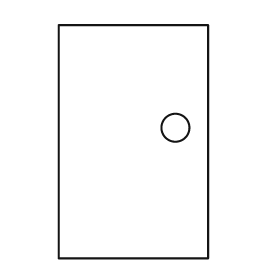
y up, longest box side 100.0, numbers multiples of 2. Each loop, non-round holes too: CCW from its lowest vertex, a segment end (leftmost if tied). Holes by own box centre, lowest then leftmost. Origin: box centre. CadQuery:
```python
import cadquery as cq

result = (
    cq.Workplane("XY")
    .moveTo(-32.0, -50.0)
    .lineTo(32.0, -50.0)
    .lineTo(32.0, 50.0)
    .lineTo(-32.0, 50.0)
    .close()
    .moveTo(18.0, 6.0)
    .circle(6.0)
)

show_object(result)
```